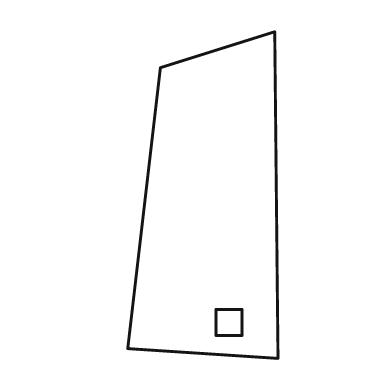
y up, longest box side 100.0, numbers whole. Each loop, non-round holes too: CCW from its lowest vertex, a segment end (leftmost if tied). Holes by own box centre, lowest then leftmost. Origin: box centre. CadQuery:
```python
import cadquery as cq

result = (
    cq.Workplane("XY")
    .moveTo(23.0, -50.0)
    .lineTo(22.0, 50.0)
    .lineTo(-13.0, 39.0)
    .lineTo(-23.0, -47.0)
    .close()
    .moveTo(4.0, -43.0)
    .lineTo(12.0, -43.0)
    .lineTo(12.0, -35.0)
    .lineTo(4.0, -35.0)
    .close()
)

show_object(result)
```